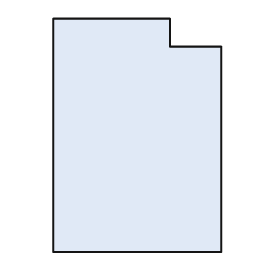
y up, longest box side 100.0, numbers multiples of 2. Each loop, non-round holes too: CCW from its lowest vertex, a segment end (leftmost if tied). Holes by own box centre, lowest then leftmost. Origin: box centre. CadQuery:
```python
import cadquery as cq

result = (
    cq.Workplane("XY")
    .moveTo(-36.0, -50.0)
    .lineTo(36.0, -50.0)
    .lineTo(36.0, 38.0)
    .lineTo(14.0, 38.0)
    .lineTo(14.0, 50.0)
    .lineTo(-36.0, 50.0)
    .close()
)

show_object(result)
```